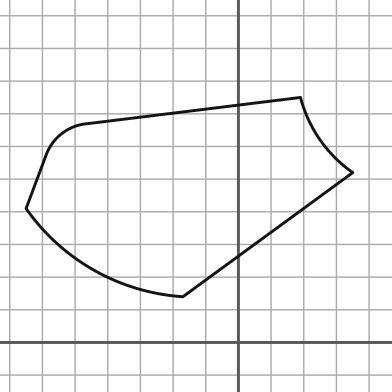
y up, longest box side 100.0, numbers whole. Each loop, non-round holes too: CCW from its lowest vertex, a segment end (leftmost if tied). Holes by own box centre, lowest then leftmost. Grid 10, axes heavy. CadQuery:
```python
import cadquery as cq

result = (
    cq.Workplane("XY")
    .moveTo(-17.0, 14.0)
    .lineTo(35.0, 52.0)
    .threePointArc((25.0, 62.0), (19.0, 75.0))
    .lineTo(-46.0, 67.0)
    .threePointArc((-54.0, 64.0), (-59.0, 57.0))
    .lineTo(-65.0, 41.0)
    .threePointArc((-44.0, 22.0), (-17.0, 14.0))
    .close()
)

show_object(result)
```